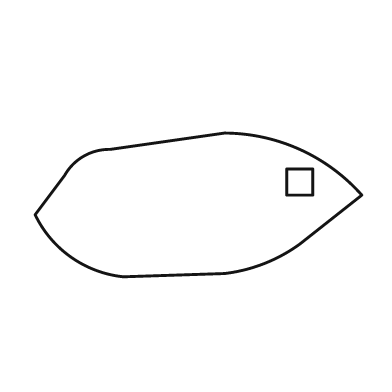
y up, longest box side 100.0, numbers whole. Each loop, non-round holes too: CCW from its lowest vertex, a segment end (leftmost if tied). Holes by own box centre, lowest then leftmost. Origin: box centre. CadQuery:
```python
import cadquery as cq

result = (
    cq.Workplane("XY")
    .moveTo(-23.0, -22.0)
    .lineTo(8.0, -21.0)
    .threePointArc((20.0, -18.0), (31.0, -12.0))
    .lineTo(50.0, 3.0)
    .threePointArc((31.0, 17.0), (8.0, 22.0))
    .lineTo(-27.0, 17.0)
    .threePointArc((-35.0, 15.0), (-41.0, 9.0))
    .lineTo(-50.0, -3.0)
    .threePointArc((-39.0, -16.0), (-23.0, -22.0))
    .close()
    .moveTo(27.0, 3.0)
    .lineTo(35.0, 3.0)
    .lineTo(35.0, 11.0)
    .lineTo(27.0, 11.0)
    .close()
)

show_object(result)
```